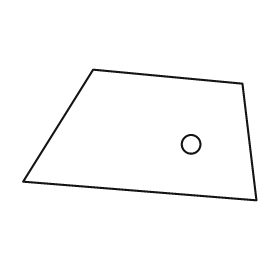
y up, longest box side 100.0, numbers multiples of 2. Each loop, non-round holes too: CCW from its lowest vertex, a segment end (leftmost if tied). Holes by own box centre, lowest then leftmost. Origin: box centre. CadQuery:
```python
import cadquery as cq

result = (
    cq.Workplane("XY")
    .moveTo(50.0, -28.0)
    .lineTo(44.0, 22.0)
    .lineTo(-20.0, 28.0)
    .lineTo(-50.0, -20.0)
    .close()
    .moveTo(22.0, -4.0)
    .circle(4.0)
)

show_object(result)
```